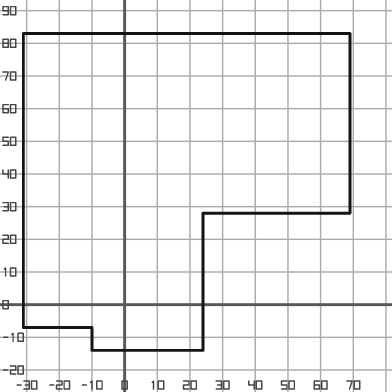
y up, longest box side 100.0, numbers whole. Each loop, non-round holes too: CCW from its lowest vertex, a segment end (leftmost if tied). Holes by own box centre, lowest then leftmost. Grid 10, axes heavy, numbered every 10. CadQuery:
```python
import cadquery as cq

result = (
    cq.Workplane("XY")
    .moveTo(-10.0, -14.0)
    .lineTo(24.0, -14.0)
    .lineTo(24.0, 28.0)
    .lineTo(69.0, 28.0)
    .lineTo(69.0, 83.0)
    .lineTo(-31.0, 83.0)
    .lineTo(-31.0, -7.0)
    .lineTo(-10.0, -7.0)
    .close()
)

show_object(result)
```